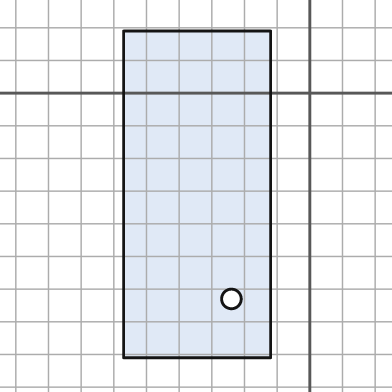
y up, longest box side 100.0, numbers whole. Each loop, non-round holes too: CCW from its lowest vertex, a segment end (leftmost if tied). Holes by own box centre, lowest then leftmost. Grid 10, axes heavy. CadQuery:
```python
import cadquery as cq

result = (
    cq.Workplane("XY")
    .moveTo(-57.0, -81.0)
    .lineTo(-12.0, -81.0)
    .lineTo(-12.0, 19.0)
    .lineTo(-57.0, 19.0)
    .close()
    .moveTo(-24.0, -63.0)
    .circle(3.0)
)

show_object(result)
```